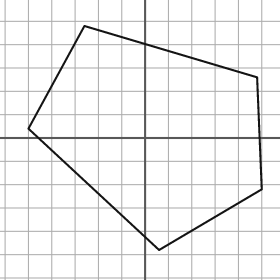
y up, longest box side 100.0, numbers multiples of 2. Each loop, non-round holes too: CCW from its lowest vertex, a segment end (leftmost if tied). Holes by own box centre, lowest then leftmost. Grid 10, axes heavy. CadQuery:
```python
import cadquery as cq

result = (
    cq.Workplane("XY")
    .moveTo(6.0, -48.0)
    .lineTo(50.0, -22.0)
    .lineTo(48.0, 26.0)
    .lineTo(-26.0, 48.0)
    .lineTo(-50.0, 4.0)
    .close()
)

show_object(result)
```